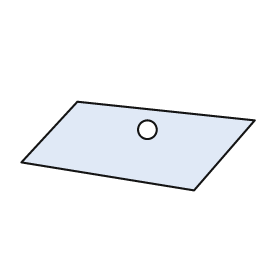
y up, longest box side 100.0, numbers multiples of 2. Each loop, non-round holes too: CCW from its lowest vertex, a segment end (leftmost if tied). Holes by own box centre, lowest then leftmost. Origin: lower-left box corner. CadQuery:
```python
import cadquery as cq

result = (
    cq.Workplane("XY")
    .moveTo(74.0, 0.0)
    .lineTo(100.0, 30.0)
    .lineTo(24.0, 38.0)
    .lineTo(0.0, 12.0)
    .close()
    .moveTo(54.0, 26.0)
    .circle(4.0)
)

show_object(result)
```